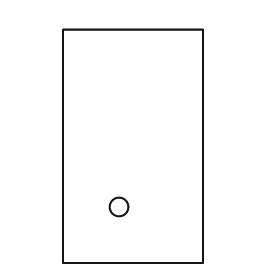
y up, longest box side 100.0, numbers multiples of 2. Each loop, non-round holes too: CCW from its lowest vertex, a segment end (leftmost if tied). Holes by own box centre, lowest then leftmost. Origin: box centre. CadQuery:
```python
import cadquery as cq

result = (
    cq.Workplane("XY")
    .moveTo(-30.0, -50.0)
    .lineTo(30.0, -50.0)
    .lineTo(30.0, 50.0)
    .lineTo(-30.0, 50.0)
    .close()
    .moveTo(-6.0, -26.0)
    .circle(4.0)
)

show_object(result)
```